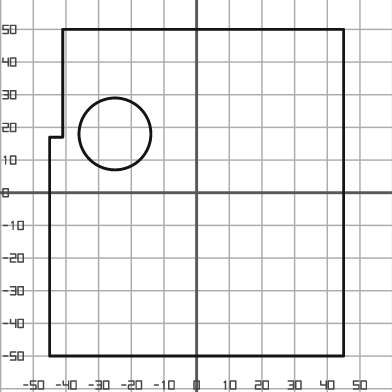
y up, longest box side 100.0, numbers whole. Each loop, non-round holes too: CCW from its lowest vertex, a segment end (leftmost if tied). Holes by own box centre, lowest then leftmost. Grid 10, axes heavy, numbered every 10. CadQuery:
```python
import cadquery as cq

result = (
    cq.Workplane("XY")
    .moveTo(-45.0, -50.0)
    .lineTo(45.0, -50.0)
    .lineTo(45.0, 50.0)
    .lineTo(-41.0, 50.0)
    .lineTo(-41.0, 17.0)
    .lineTo(-45.0, 17.0)
    .close()
    .moveTo(-25.0, 18.0)
    .circle(11.0)
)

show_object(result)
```